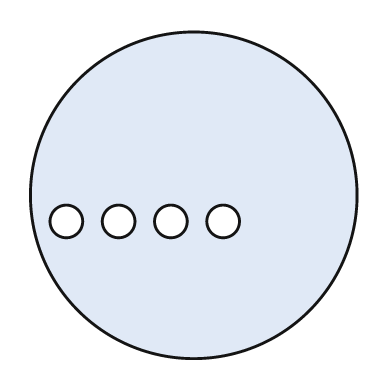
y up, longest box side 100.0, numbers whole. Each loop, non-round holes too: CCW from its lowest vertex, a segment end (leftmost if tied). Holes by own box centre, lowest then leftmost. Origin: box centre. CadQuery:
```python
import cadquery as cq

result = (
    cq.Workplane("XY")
    .moveTo(0.0, 0.0)
    .circle(50.0)
    .moveTo(-39.0, -8.0)
    .circle(5.0)
    .moveTo(-23.0, -8.0)
    .circle(5.0)
    .moveTo(-7.0, -8.0)
    .circle(5.0)
    .moveTo(9.0, -8.0)
    .circle(5.0)
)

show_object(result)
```